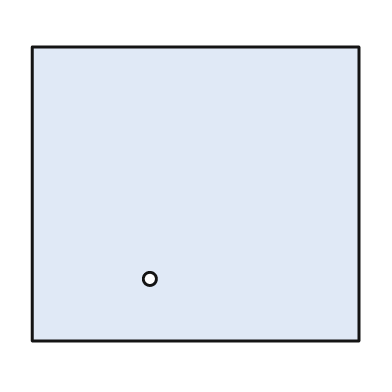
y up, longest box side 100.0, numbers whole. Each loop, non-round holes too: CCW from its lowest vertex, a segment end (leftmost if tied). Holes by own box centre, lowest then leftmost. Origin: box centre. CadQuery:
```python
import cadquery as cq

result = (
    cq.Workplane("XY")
    .moveTo(-50.0, -45.0)
    .lineTo(50.0, -45.0)
    .lineTo(50.0, 45.0)
    .lineTo(-50.0, 45.0)
    .close()
    .moveTo(-14.0, -26.0)
    .circle(2.0)
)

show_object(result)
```